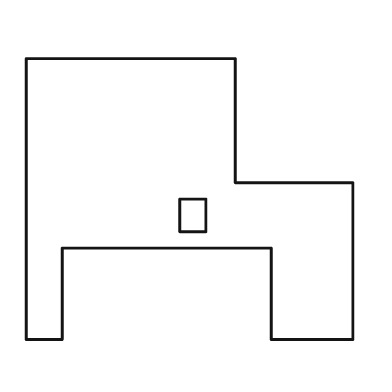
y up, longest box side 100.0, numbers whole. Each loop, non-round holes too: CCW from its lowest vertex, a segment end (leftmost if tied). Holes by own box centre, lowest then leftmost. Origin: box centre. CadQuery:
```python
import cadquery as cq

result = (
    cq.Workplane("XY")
    .moveTo(-50.0, -43.0)
    .lineTo(-39.0, -43.0)
    .lineTo(-39.0, -15.0)
    .lineTo(25.0, -15.0)
    .lineTo(25.0, -43.0)
    .lineTo(50.0, -43.0)
    .lineTo(50.0, 5.0)
    .lineTo(14.0, 5.0)
    .lineTo(14.0, 43.0)
    .lineTo(-50.0, 43.0)
    .close()
    .moveTo(-3.0, -10.0)
    .lineTo(5.0, -10.0)
    .lineTo(5.0, 0.0)
    .lineTo(-3.0, 0.0)
    .close()
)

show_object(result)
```